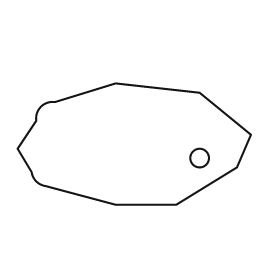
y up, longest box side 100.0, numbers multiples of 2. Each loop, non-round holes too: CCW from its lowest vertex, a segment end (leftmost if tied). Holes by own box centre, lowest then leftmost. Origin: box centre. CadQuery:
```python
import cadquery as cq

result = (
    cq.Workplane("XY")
    .moveTo(-8.0, -26.0)
    .lineTo(18.0, -26.0)
    .lineTo(44.0, -10.0)
    .lineTo(50.0, 4.0)
    .lineTo(28.0, 22.0)
    .lineTo(-8.0, 26.0)
    .lineTo(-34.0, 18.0)
    .threePointArc((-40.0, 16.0), (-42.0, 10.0))
    .lineTo(-50.0, -2.0)
    .lineTo(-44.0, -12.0)
    .threePointArc((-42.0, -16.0), (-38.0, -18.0))
    .close()
    .moveTo(28.0, -6.0)
    .circle(4.0)
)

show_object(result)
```